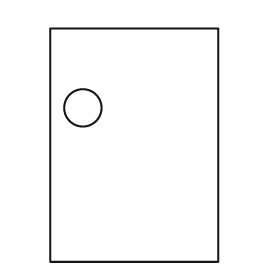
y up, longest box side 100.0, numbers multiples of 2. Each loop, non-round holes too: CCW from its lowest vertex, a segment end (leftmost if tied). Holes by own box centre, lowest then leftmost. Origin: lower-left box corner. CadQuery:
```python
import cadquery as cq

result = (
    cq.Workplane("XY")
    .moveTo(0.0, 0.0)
    .lineTo(72.0, 0.0)
    .lineTo(72.0, 100.0)
    .lineTo(0.0, 100.0)
    .close()
    .moveTo(14.0, 66.0)
    .circle(8.0)
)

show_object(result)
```